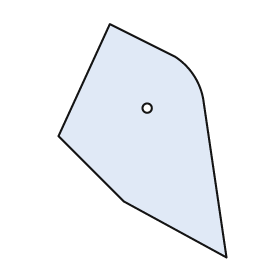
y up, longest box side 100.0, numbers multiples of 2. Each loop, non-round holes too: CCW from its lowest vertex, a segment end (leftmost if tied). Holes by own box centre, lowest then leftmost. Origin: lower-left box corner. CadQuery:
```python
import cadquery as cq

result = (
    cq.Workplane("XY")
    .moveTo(72.0, 0.0)
    .lineTo(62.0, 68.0)
    .threePointArc((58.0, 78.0), (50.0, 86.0))
    .lineTo(22.0, 100.0)
    .lineTo(0.0, 52.0)
    .lineTo(28.0, 24.0)
    .close()
    .moveTo(38.0, 64.0)
    .circle(2.0)
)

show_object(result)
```